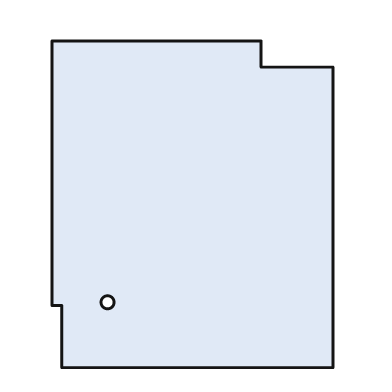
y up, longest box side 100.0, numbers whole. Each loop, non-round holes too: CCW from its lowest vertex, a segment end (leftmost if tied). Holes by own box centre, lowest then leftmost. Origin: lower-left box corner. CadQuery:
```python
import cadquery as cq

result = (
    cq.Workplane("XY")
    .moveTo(3.0, 0.0)
    .lineTo(86.0, 0.0)
    .lineTo(86.0, 92.0)
    .lineTo(64.0, 92.0)
    .lineTo(64.0, 100.0)
    .lineTo(0.0, 100.0)
    .lineTo(0.0, 19.0)
    .lineTo(3.0, 19.0)
    .close()
    .moveTo(17.0, 20.0)
    .circle(2.0)
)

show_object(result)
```